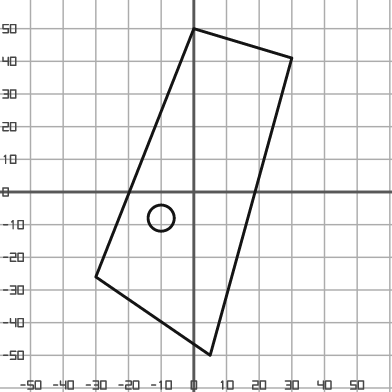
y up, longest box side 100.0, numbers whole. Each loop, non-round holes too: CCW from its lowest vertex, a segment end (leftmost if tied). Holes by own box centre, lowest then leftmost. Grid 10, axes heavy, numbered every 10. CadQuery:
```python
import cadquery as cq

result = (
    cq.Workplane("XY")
    .moveTo(5.0, -50.0)
    .lineTo(30.0, 41.0)
    .lineTo(0.0, 50.0)
    .lineTo(-30.0, -26.0)
    .close()
    .moveTo(-10.0, -8.0)
    .circle(4.0)
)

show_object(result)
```